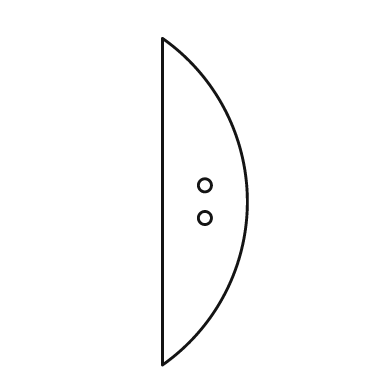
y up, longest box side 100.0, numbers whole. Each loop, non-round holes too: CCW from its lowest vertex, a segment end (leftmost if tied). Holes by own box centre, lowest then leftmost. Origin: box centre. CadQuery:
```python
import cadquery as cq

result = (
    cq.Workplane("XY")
    .moveTo(-13.0, -50.0)
    .threePointArc((13.0, 0.0), (-13.0, 50.0))
    .close()
    .moveTo(0.0, -5.0)
    .circle(2.0)
    .moveTo(0.0, 5.0)
    .circle(2.0)
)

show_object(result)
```